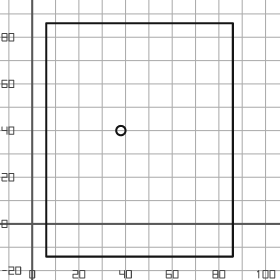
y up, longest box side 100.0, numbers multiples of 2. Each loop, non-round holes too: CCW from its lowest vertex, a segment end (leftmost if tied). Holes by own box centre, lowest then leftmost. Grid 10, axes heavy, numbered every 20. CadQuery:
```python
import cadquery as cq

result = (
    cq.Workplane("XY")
    .moveTo(6.0, -14.0)
    .lineTo(86.0, -14.0)
    .lineTo(86.0, 86.0)
    .lineTo(6.0, 86.0)
    .close()
    .moveTo(38.0, 40.0)
    .circle(2.0)
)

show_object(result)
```